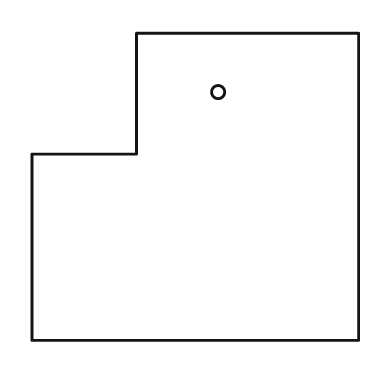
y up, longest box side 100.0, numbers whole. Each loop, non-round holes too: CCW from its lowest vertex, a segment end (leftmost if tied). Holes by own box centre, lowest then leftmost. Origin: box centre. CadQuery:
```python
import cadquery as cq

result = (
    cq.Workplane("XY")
    .moveTo(-50.0, -47.0)
    .lineTo(50.0, -47.0)
    .lineTo(50.0, 47.0)
    .lineTo(-18.0, 47.0)
    .lineTo(-18.0, 10.0)
    .lineTo(-50.0, 10.0)
    .close()
    .moveTo(7.0, 29.0)
    .circle(2.0)
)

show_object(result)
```